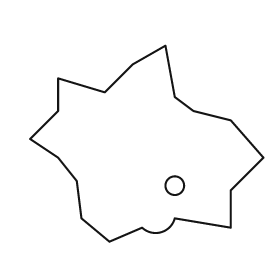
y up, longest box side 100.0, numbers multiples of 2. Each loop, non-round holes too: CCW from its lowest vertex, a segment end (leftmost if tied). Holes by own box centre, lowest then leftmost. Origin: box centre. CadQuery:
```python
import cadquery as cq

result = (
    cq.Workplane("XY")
    .moveTo(-16.0, -42.0)
    .lineTo(-2.0, -36.0)
    .threePointArc((6.0, -38.0), (12.0, -32.0))
    .lineTo(36.0, -36.0)
    .lineTo(36.0, -20.0)
    .lineTo(50.0, -6.0)
    .lineTo(36.0, 10.0)
    .lineTo(20.0, 14.0)
    .lineTo(12.0, 20.0)
    .lineTo(8.0, 42.0)
    .lineTo(-6.0, 34.0)
    .lineTo(-18.0, 22.0)
    .lineTo(-38.0, 28.0)
    .lineTo(-38.0, 14.0)
    .lineTo(-50.0, 2.0)
    .lineTo(-38.0, -6.0)
    .lineTo(-30.0, -16.0)
    .lineTo(-28.0, -32.0)
    .close()
    .moveTo(12.0, -18.0)
    .circle(4.0)
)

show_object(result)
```